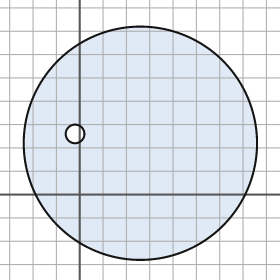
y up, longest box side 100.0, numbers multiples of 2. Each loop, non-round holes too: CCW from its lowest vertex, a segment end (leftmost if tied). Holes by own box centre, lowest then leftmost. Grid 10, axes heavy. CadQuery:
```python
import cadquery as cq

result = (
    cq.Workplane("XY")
    .moveTo(26.0, 22.0)
    .circle(50.0)
    .moveTo(-2.0, 26.0)
    .circle(4.0)
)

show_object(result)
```